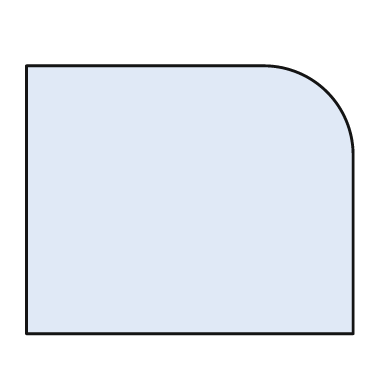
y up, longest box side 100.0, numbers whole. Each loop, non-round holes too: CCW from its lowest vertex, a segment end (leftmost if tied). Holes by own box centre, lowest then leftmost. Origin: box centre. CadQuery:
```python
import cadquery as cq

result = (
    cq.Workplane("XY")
    .moveTo(-50.0, -41.0)
    .lineTo(50.0, -41.0)
    .lineTo(50.0, 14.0)
    .threePointArc((42.0, 33.0), (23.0, 41.0))
    .lineTo(-50.0, 41.0)
    .close()
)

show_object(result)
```